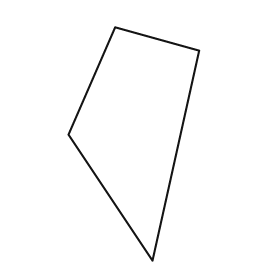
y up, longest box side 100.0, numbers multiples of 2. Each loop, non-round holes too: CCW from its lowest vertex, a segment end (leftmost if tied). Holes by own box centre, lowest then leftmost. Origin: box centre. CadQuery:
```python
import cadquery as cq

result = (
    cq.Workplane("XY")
    .moveTo(8.0, -50.0)
    .lineTo(28.0, 40.0)
    .lineTo(-8.0, 50.0)
    .lineTo(-28.0, 4.0)
    .close()
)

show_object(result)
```